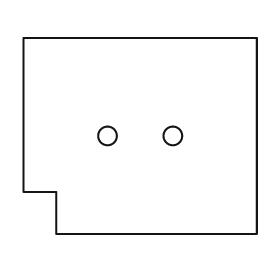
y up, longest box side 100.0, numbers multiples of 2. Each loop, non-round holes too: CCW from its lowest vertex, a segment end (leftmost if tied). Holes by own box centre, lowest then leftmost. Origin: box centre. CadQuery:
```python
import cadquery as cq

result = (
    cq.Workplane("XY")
    .moveTo(-36.0, -42.0)
    .lineTo(50.0, -42.0)
    .lineTo(50.0, 42.0)
    .lineTo(-50.0, 42.0)
    .lineTo(-50.0, -24.0)
    .lineTo(-36.0, -24.0)
    .close()
    .moveTo(-14.0, 0.0)
    .circle(4.0)
    .moveTo(14.0, 0.0)
    .circle(4.0)
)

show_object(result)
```